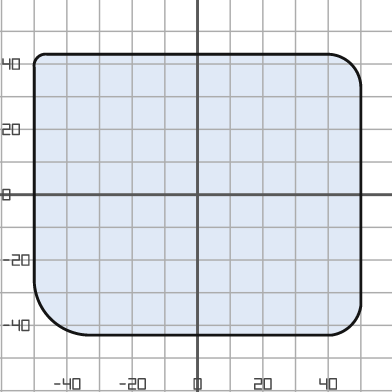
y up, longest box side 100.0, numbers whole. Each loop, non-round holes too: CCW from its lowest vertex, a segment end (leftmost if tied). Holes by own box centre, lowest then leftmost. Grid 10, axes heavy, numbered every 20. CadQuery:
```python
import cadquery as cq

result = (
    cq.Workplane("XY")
    .moveTo(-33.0, -43.0)
    .lineTo(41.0, -43.0)
    .threePointArc((47.0, -40.0), (50.0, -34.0))
    .lineTo(50.0, 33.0)
    .threePointArc((47.0, 40.0), (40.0, 43.0))
    .lineTo(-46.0, 43.0)
    .threePointArc((-49.0, 42.0), (-50.0, 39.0))
    .lineTo(-50.0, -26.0)
    .threePointArc((-45.0, -38.0), (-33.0, -43.0))
    .close()
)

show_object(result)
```